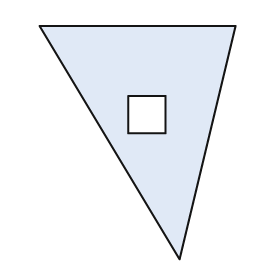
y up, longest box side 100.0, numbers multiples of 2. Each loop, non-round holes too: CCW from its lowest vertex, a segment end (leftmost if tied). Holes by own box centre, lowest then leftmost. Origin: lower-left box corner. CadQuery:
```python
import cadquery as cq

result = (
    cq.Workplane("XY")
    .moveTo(60.0, 0.0)
    .lineTo(84.0, 100.0)
    .lineTo(0.0, 100.0)
    .close()
    .moveTo(38.0, 54.0)
    .lineTo(54.0, 54.0)
    .lineTo(54.0, 70.0)
    .lineTo(38.0, 70.0)
    .close()
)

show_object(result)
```